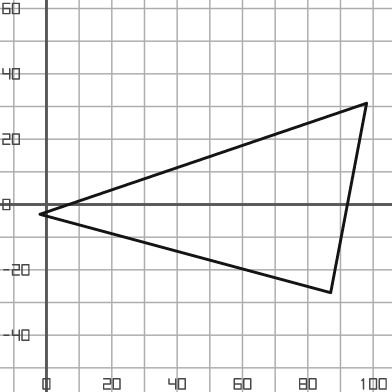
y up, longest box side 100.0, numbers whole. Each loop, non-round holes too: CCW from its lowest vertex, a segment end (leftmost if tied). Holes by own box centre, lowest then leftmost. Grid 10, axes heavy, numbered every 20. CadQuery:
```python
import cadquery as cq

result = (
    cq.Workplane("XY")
    .moveTo(87.0, -27.0)
    .lineTo(98.0, 31.0)
    .lineTo(-2.0, -3.0)
    .close()
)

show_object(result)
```